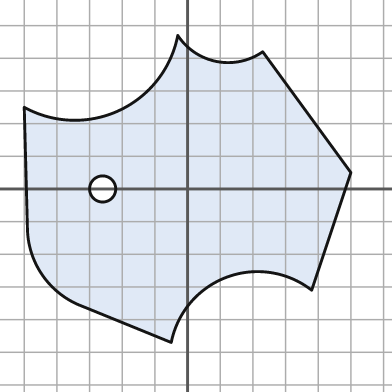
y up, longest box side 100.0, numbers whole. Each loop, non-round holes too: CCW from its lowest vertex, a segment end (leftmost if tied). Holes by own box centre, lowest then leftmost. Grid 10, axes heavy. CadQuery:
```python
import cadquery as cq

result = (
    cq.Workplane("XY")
    .moveTo(-5.0, -47.0)
    .threePointArc((12.0, -27.0), (38.0, -31.0))
    .lineTo(50.0, 5.0)
    .lineTo(23.0, 42.0)
    .threePointArc((9.0, 39.0), (-3.0, 47.0))
    .threePointArc((-21.0, 24.0), (-50.0, 25.0))
    .lineTo(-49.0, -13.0)
    .threePointArc((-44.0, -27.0), (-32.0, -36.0))
    .close()
    .moveTo(-26.0, 0.0)
    .circle(4.0)
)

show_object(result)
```